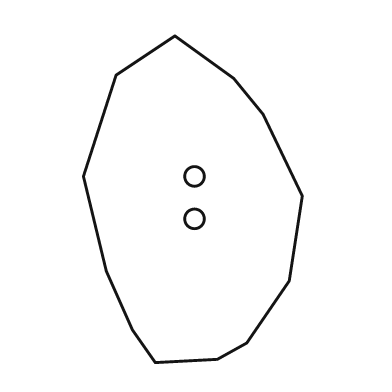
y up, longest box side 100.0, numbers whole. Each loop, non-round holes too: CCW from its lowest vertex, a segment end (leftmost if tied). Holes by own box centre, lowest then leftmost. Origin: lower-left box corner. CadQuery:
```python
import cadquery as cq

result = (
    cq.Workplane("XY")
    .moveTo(22.0, 0.0)
    .lineTo(41.0, 1.0)
    .lineTo(50.0, 6.0)
    .lineTo(63.0, 25.0)
    .lineTo(67.0, 51.0)
    .lineTo(55.0, 76.0)
    .lineTo(46.0, 87.0)
    .lineTo(28.0, 100.0)
    .lineTo(10.0, 88.0)
    .lineTo(0.0, 57.0)
    .lineTo(7.0, 28.0)
    .lineTo(15.0, 10.0)
    .close()
    .moveTo(34.0, 44.0)
    .circle(3.0)
    .moveTo(34.0, 57.0)
    .circle(3.0)
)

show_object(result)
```